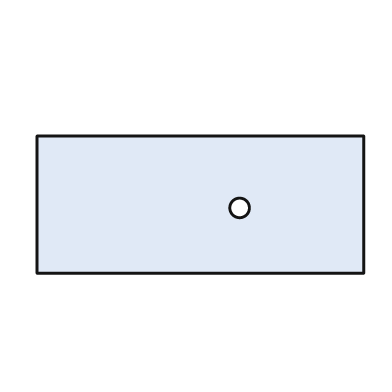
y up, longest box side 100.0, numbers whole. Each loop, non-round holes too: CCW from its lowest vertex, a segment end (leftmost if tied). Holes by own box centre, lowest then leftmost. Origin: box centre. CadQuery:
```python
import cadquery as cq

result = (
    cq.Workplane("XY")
    .moveTo(-50.0, -21.0)
    .lineTo(50.0, -21.0)
    .lineTo(50.0, 21.0)
    .lineTo(-50.0, 21.0)
    .close()
    .moveTo(12.0, -1.0)
    .circle(3.0)
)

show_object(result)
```